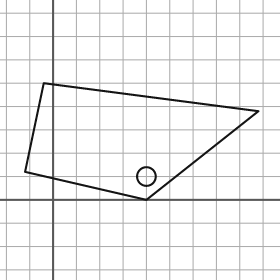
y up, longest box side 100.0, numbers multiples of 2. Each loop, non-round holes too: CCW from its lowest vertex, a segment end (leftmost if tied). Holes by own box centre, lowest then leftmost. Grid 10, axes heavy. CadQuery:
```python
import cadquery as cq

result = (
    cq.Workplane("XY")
    .moveTo(40.0, 0.0)
    .lineTo(88.0, 38.0)
    .lineTo(-4.0, 50.0)
    .lineTo(-12.0, 12.0)
    .close()
    .moveTo(40.0, 10.0)
    .circle(4.0)
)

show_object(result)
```